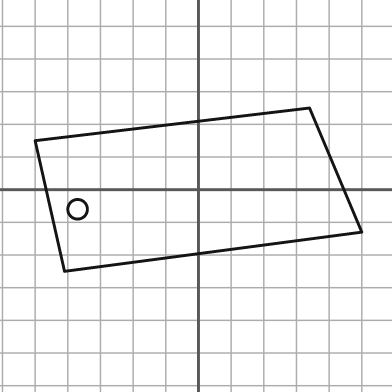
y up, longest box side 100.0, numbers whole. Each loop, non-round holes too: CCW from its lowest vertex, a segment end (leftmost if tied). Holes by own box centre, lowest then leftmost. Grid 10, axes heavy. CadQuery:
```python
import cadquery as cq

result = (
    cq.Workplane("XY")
    .moveTo(-41.0, -25.0)
    .lineTo(50.0, -13.0)
    .lineTo(34.0, 25.0)
    .lineTo(-50.0, 15.0)
    .close()
    .moveTo(-37.0, -6.0)
    .circle(3.0)
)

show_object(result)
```